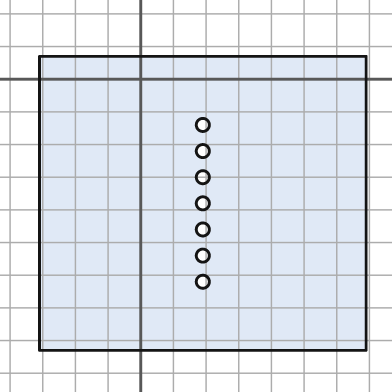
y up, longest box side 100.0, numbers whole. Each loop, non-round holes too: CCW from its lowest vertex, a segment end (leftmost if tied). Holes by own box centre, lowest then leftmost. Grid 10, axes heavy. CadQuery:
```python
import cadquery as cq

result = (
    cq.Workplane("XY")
    .moveTo(-31.0, -83.0)
    .lineTo(69.0, -83.0)
    .lineTo(69.0, 7.0)
    .lineTo(-31.0, 7.0)
    .close()
    .moveTo(19.0, -62.0)
    .circle(2.0)
    .moveTo(19.0, -54.0)
    .circle(2.0)
    .moveTo(19.0, -46.0)
    .circle(2.0)
    .moveTo(19.0, -38.0)
    .circle(2.0)
    .moveTo(19.0, -30.0)
    .circle(2.0)
    .moveTo(19.0, -22.0)
    .circle(2.0)
    .moveTo(19.0, -14.0)
    .circle(2.0)
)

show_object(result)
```